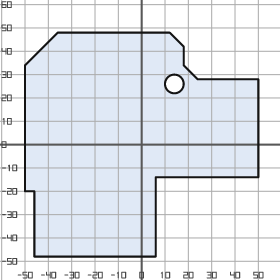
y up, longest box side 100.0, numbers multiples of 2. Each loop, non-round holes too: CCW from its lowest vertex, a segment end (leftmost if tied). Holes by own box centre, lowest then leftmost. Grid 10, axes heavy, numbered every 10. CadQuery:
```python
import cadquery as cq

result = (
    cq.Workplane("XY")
    .moveTo(-46.0, -48.0)
    .lineTo(6.0, -48.0)
    .lineTo(6.0, -14.0)
    .lineTo(50.0, -14.0)
    .lineTo(50.0, 28.0)
    .lineTo(24.0, 28.0)
    .lineTo(18.0, 34.0)
    .lineTo(18.0, 42.0)
    .lineTo(12.0, 48.0)
    .lineTo(-36.0, 48.0)
    .lineTo(-50.0, 34.0)
    .lineTo(-50.0, -20.0)
    .lineTo(-46.0, -20.0)
    .close()
    .moveTo(14.0, 26.0)
    .circle(4.0)
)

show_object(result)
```